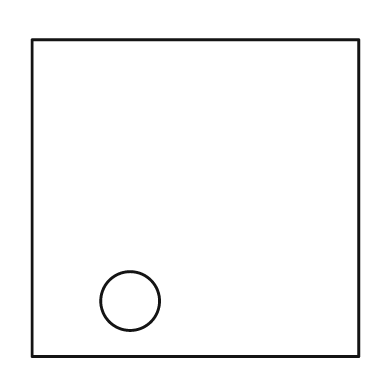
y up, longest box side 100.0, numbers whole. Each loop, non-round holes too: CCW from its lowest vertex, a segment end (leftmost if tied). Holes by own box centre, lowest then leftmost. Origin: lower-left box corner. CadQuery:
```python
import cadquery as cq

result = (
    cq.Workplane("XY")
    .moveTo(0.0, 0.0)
    .lineTo(100.0, 0.0)
    .lineTo(100.0, 97.0)
    .lineTo(0.0, 97.0)
    .close()
    .moveTo(30.0, 17.0)
    .circle(9.0)
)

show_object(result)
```